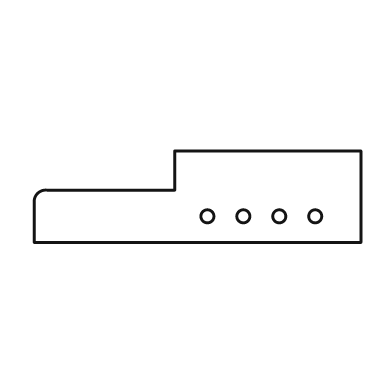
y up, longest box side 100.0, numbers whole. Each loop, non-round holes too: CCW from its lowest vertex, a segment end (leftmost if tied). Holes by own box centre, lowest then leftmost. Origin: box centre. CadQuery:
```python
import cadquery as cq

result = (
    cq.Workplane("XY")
    .moveTo(-50.0, -14.0)
    .lineTo(50.0, -14.0)
    .lineTo(50.0, 14.0)
    .lineTo(-7.0, 14.0)
    .lineTo(-7.0, 2.0)
    .lineTo(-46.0, 2.0)
    .threePointArc((-49.0, 1.0), (-50.0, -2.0))
    .close()
    .moveTo(3.0, -6.0)
    .circle(2.0)
    .moveTo(14.0, -6.0)
    .circle(2.0)
    .moveTo(25.0, -6.0)
    .circle(2.0)
    .moveTo(36.0, -6.0)
    .circle(2.0)
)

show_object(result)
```